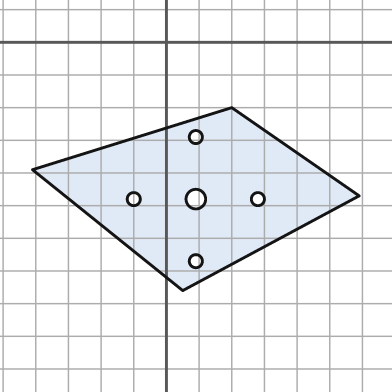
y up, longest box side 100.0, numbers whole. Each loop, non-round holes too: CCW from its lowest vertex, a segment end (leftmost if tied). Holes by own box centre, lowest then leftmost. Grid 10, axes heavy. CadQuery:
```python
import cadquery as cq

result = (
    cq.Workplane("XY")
    .moveTo(5.0, -76.0)
    .lineTo(59.0, -47.0)
    .lineTo(20.0, -20.0)
    .lineTo(-41.0, -39.0)
    .close()
    .moveTo(9.0, -67.0)
    .circle(2.0)
    .moveTo(-10.0, -48.0)
    .circle(2.0)
    .moveTo(9.0, -48.0)
    .circle(3.0)
    .moveTo(28.0, -48.0)
    .circle(2.0)
    .moveTo(9.0, -29.0)
    .circle(2.0)
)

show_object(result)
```